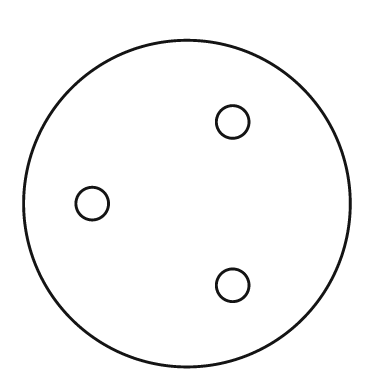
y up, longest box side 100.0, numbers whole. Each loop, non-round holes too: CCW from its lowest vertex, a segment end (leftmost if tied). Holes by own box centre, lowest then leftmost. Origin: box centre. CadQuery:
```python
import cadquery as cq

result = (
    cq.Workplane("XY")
    .moveTo(0.0, 0.0)
    .circle(50.0)
    .moveTo(14.0, -25.0)
    .circle(5.0)
    .moveTo(-29.0, 0.0)
    .circle(5.0)
    .moveTo(14.0, 25.0)
    .circle(5.0)
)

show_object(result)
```